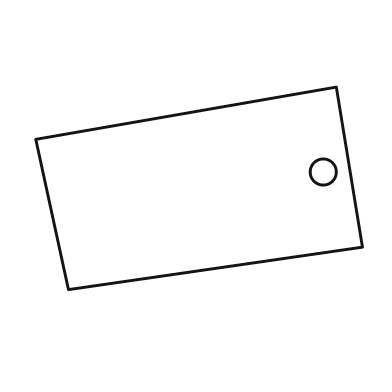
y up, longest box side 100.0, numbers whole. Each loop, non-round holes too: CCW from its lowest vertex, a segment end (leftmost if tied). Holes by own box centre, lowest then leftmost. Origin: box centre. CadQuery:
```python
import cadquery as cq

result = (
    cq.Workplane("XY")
    .moveTo(-40.0, -31.0)
    .lineTo(50.0, -18.0)
    .lineTo(42.0, 31.0)
    .lineTo(-50.0, 15.0)
    .close()
    .moveTo(38.0, 5.0)
    .circle(4.0)
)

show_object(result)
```